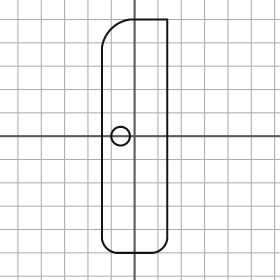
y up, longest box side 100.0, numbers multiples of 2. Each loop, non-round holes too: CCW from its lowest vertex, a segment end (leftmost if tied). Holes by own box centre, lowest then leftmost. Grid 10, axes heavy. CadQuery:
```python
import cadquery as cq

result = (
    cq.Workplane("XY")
    .moveTo(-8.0, -50.0)
    .lineTo(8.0, -50.0)
    .threePointArc((12.0, -48.0), (14.0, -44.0))
    .lineTo(14.0, 50.0)
    .lineTo(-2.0, 50.0)
    .threePointArc((-10.0, 46.0), (-14.0, 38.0))
    .lineTo(-14.0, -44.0)
    .threePointArc((-12.0, -48.0), (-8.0, -50.0))
    .close()
    .moveTo(-6.0, 0.0)
    .circle(4.0)
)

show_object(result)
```